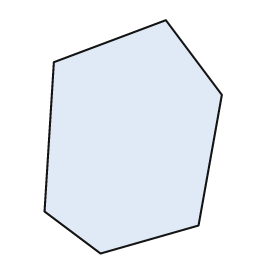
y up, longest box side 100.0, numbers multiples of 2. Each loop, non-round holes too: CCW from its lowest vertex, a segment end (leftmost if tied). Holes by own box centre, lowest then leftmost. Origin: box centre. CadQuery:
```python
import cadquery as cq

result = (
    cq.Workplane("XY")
    .moveTo(-14.0, -50.0)
    .lineTo(28.0, -38.0)
    .lineTo(38.0, 18.0)
    .lineTo(14.0, 50.0)
    .lineTo(-34.0, 32.0)
    .lineTo(-38.0, -32.0)
    .close()
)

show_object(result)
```